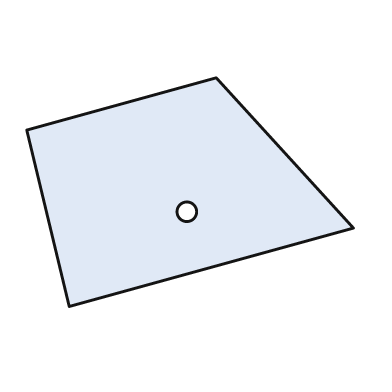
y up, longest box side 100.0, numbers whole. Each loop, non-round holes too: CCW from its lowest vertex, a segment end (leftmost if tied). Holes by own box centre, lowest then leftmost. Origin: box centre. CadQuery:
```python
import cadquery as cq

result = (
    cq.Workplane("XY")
    .moveTo(-37.0, -35.0)
    .lineTo(50.0, -11.0)
    .lineTo(8.0, 35.0)
    .lineTo(-50.0, 19.0)
    .close()
    .moveTo(-1.0, -6.0)
    .circle(3.0)
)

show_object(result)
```